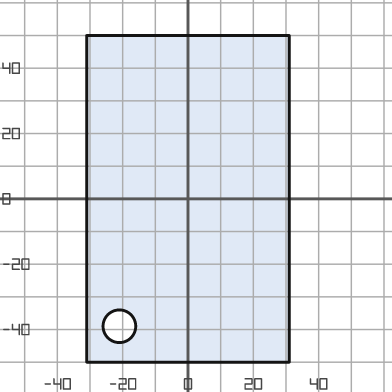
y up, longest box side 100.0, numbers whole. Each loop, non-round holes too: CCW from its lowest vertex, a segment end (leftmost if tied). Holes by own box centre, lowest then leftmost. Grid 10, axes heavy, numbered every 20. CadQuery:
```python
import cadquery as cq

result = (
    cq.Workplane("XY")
    .moveTo(-31.0, -50.0)
    .lineTo(31.0, -50.0)
    .lineTo(31.0, 50.0)
    .lineTo(-31.0, 50.0)
    .close()
    .moveTo(-21.0, -39.0)
    .circle(5.0)
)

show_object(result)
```